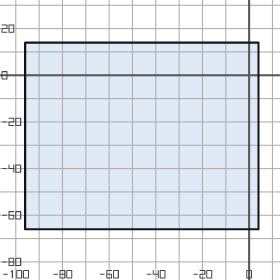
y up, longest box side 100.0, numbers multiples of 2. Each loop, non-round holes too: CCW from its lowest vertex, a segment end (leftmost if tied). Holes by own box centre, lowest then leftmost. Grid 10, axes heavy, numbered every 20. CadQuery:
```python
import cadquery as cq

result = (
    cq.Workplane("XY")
    .moveTo(-96.0, -66.0)
    .lineTo(4.0, -66.0)
    .lineTo(4.0, 14.0)
    .lineTo(-96.0, 14.0)
    .close()
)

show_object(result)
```